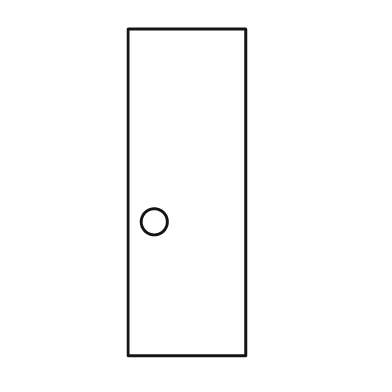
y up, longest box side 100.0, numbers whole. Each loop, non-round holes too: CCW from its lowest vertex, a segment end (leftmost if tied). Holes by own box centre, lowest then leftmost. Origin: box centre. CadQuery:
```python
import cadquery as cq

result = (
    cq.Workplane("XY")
    .moveTo(-18.0, -50.0)
    .lineTo(18.0, -50.0)
    .lineTo(18.0, 50.0)
    .lineTo(-18.0, 50.0)
    .close()
    .moveTo(-10.0, -9.0)
    .circle(4.0)
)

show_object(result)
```